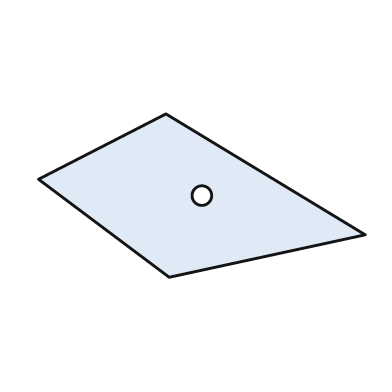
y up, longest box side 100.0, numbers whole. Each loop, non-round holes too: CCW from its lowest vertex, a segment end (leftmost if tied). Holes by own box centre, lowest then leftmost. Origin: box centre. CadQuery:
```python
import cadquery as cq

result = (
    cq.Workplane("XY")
    .moveTo(-10.0, -25.0)
    .lineTo(50.0, -12.0)
    .lineTo(-11.0, 25.0)
    .lineTo(-50.0, 5.0)
    .close()
    .moveTo(0.0, 0.0)
    .circle(3.0)
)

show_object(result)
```